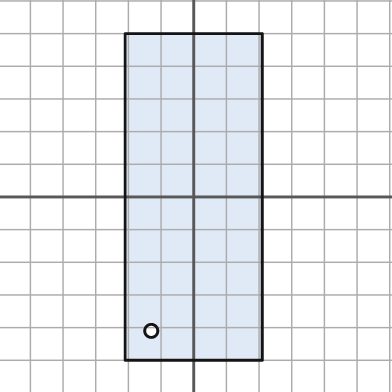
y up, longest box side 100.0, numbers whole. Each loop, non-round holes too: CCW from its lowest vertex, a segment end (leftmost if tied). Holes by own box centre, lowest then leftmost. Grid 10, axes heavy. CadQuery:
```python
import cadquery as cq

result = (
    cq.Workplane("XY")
    .moveTo(-21.0, -50.0)
    .lineTo(21.0, -50.0)
    .lineTo(21.0, 50.0)
    .lineTo(-21.0, 50.0)
    .close()
    .moveTo(-13.0, -41.0)
    .circle(2.0)
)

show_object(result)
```